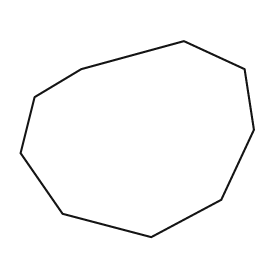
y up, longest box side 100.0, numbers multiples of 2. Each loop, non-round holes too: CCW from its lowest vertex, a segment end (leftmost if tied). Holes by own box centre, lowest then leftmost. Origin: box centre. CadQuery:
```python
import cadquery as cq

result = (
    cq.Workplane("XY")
    .moveTo(6.0, -42.0)
    .lineTo(36.0, -26.0)
    .lineTo(50.0, 4.0)
    .lineTo(46.0, 30.0)
    .lineTo(20.0, 42.0)
    .lineTo(-24.0, 30.0)
    .lineTo(-44.0, 18.0)
    .lineTo(-50.0, -6.0)
    .lineTo(-32.0, -32.0)
    .close()
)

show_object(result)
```